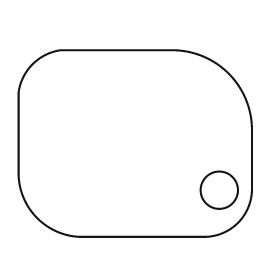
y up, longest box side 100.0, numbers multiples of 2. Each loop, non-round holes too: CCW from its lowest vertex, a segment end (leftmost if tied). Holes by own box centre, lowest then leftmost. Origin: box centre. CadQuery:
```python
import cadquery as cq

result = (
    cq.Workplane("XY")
    .moveTo(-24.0, -40.0)
    .lineTo(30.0, -40.0)
    .threePointArc((44.0, -34.0), (50.0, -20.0))
    .lineTo(50.0, 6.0)
    .threePointArc((40.0, 30.0), (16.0, 40.0))
    .lineTo(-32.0, 40.0)
    .threePointArc((-44.0, 34.0), (-50.0, 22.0))
    .lineTo(-50.0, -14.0)
    .threePointArc((-42.0, -32.0), (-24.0, -40.0))
    .close()
    .moveTo(36.0, -20.0)
    .circle(8.0)
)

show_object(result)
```